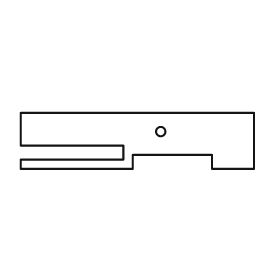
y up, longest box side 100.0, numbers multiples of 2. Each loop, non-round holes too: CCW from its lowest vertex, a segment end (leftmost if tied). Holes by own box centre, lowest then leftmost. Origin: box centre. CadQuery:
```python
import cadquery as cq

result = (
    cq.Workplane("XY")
    .moveTo(-50.0, -12.0)
    .lineTo(-2.0, -12.0)
    .lineTo(-2.0, -6.0)
    .lineTo(32.0, -6.0)
    .lineTo(32.0, -12.0)
    .lineTo(50.0, -12.0)
    .lineTo(50.0, 12.0)
    .lineTo(-50.0, 12.0)
    .lineTo(-50.0, -2.0)
    .lineTo(-6.0, -2.0)
    .lineTo(-6.0, -8.0)
    .lineTo(-50.0, -8.0)
    .close()
    .moveTo(10.0, 4.0)
    .circle(2.0)
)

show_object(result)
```